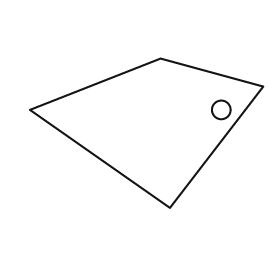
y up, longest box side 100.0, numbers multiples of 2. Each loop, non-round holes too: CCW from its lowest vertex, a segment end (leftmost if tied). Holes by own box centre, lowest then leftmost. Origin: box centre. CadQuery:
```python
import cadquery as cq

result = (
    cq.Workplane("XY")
    .moveTo(10.0, -32.0)
    .lineTo(50.0, 20.0)
    .lineTo(6.0, 32.0)
    .lineTo(-50.0, 10.0)
    .close()
    .moveTo(32.0, 10.0)
    .circle(4.0)
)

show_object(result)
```